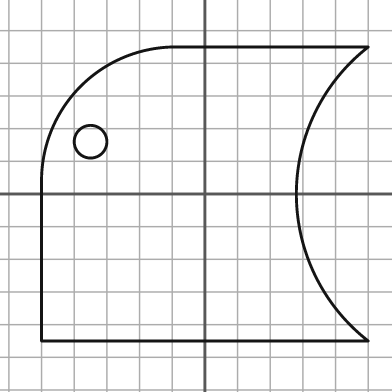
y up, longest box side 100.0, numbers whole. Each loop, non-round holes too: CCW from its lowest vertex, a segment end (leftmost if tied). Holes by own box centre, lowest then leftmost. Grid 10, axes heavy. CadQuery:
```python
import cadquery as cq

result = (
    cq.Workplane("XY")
    .moveTo(-50.0, -45.0)
    .lineTo(50.0, -45.0)
    .threePointArc((28.0, 0.0), (50.0, 45.0))
    .lineTo(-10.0, 45.0)
    .threePointArc((-38.0, 33.0), (-50.0, 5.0))
    .close()
    .moveTo(-35.0, 16.0)
    .circle(5.0)
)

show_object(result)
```